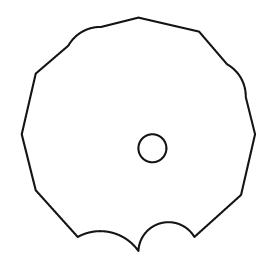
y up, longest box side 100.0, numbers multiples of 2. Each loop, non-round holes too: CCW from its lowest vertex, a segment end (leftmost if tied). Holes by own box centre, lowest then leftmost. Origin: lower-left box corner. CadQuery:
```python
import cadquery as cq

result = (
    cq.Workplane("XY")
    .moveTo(50.0, 0.0)
    .threePointArc((60.0, 12.0), (74.0, 6.0))
    .lineTo(94.0, 24.0)
    .lineTo(100.0, 50.0)
    .lineTo(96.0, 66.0)
    .threePointArc((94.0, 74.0), (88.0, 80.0))
    .lineTo(76.0, 94.0)
    .lineTo(50.0, 100.0)
    .lineTo(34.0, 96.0)
    .threePointArc((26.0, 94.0), (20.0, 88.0))
    .lineTo(6.0, 76.0)
    .lineTo(0.0, 50.0)
    .lineTo(6.0, 26.0)
    .lineTo(24.0, 6.0)
    .threePointArc((38.0, 8.0), (50.0, 0.0))
    .close()
    .moveTo(56.0, 44.0)
    .circle(6.0)
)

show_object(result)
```